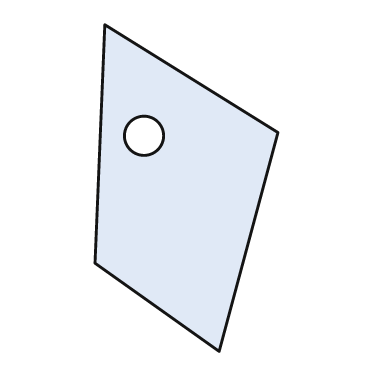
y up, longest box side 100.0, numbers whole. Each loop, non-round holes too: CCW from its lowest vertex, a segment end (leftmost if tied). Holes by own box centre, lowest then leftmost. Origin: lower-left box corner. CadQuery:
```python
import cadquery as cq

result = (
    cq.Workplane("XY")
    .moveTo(38.0, 0.0)
    .lineTo(56.0, 67.0)
    .lineTo(3.0, 100.0)
    .lineTo(0.0, 27.0)
    .close()
    .moveTo(15.0, 66.0)
    .circle(6.0)
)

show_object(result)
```